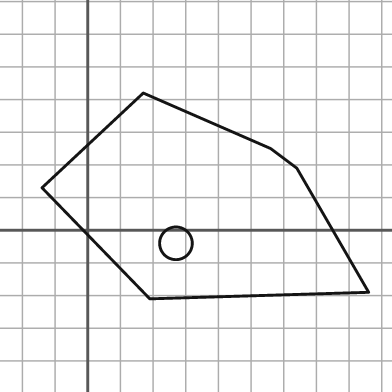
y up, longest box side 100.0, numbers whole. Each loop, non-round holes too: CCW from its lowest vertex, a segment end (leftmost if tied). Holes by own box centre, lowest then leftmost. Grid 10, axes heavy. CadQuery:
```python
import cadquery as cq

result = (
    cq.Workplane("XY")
    .moveTo(19.0, -21.0)
    .lineTo(86.0, -19.0)
    .lineTo(64.0, 19.0)
    .lineTo(56.0, 25.0)
    .lineTo(17.0, 42.0)
    .lineTo(-14.0, 13.0)
    .close()
    .moveTo(27.0, -4.0)
    .circle(5.0)
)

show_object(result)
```